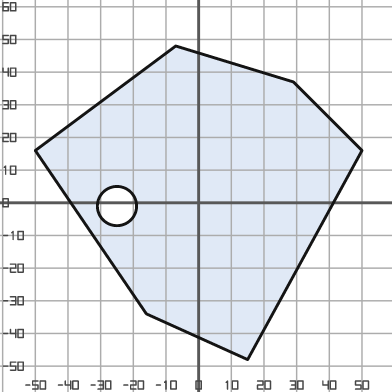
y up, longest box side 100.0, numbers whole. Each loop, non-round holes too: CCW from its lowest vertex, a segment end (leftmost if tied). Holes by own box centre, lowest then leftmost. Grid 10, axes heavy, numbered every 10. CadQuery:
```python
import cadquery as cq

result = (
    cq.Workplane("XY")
    .moveTo(15.0, -48.0)
    .lineTo(50.0, 16.0)
    .lineTo(29.0, 37.0)
    .lineTo(-7.0, 48.0)
    .lineTo(-50.0, 16.0)
    .lineTo(-16.0, -34.0)
    .close()
    .moveTo(-25.0, -1.0)
    .circle(6.0)
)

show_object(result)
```